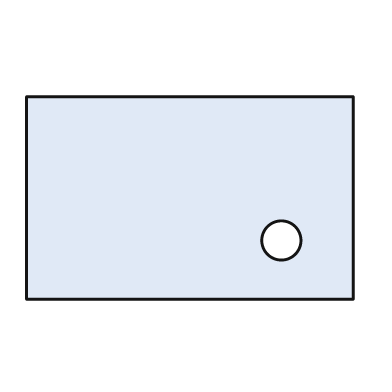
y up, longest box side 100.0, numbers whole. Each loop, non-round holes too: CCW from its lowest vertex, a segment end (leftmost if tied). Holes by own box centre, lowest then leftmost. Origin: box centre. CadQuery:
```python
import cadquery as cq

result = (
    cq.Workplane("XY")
    .moveTo(-50.0, -31.0)
    .lineTo(50.0, -31.0)
    .lineTo(50.0, 31.0)
    .lineTo(-50.0, 31.0)
    .close()
    .moveTo(28.0, -13.0)
    .circle(6.0)
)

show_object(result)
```